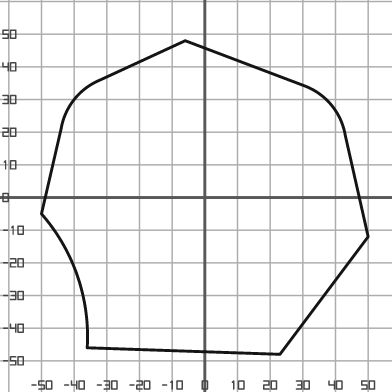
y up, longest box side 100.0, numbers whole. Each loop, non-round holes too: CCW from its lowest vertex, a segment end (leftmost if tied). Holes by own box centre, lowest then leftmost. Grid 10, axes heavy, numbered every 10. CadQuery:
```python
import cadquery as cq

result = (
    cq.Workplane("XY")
    .moveTo(23.0, -48.0)
    .lineTo(50.0, -12.0)
    .lineTo(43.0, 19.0)
    .threePointArc((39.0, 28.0), (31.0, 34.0))
    .lineTo(-6.0, 48.0)
    .lineTo(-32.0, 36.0)
    .threePointArc((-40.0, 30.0), (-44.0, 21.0))
    .lineTo(-50.0, -5.0)
    .threePointArc((-39.0, -24.0), (-36.0, -46.0))
    .close()
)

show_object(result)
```